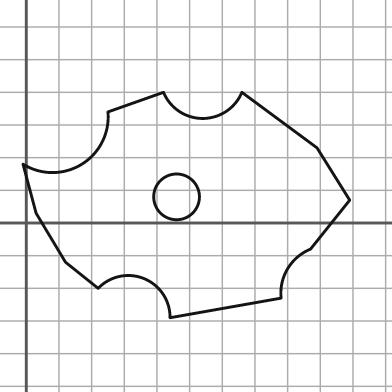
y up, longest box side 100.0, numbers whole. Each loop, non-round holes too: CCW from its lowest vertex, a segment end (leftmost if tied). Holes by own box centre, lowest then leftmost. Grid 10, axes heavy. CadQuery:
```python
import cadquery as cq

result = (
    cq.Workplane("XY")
    .moveTo(44.0, -29.0)
    .lineTo(78.0, -23.0)
    .threePointArc((80.0, -14.0), (87.0, -8.0))
    .lineTo(99.0, 7.0)
    .lineTo(89.0, 23.0)
    .lineTo(66.0, 40.0)
    .threePointArc((54.0, 32.0), (42.0, 40.0))
    .lineTo(25.0, 34.0)
    .threePointArc((17.0, 18.0), (-1.0, 18.0))
    .lineTo(3.0, 3.0)
    .lineTo(12.0, -12.0)
    .lineTo(22.0, -20.0)
    .threePointArc((36.0, -17.0), (44.0, -29.0))
    .close()
    .moveTo(46.0, 8.0)
    .circle(7.0)
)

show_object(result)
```